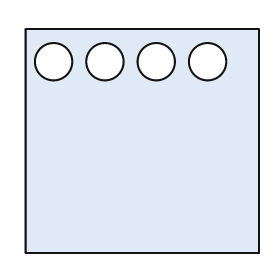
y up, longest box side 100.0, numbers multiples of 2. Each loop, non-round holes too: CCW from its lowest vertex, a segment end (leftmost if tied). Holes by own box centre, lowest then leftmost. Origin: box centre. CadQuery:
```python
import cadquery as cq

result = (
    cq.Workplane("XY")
    .moveTo(-50.0, -48.0)
    .lineTo(50.0, -48.0)
    .lineTo(50.0, 48.0)
    .lineTo(-50.0, 48.0)
    .close()
    .moveTo(-38.0, 34.0)
    .circle(8.0)
    .moveTo(-16.0, 34.0)
    .circle(8.0)
    .moveTo(6.0, 34.0)
    .circle(8.0)
    .moveTo(28.0, 34.0)
    .circle(8.0)
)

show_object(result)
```